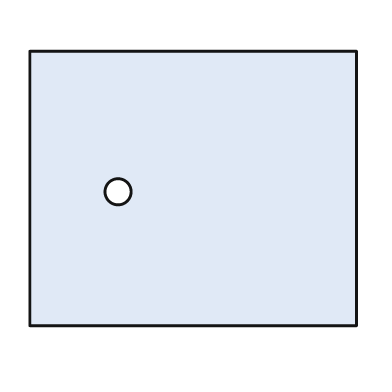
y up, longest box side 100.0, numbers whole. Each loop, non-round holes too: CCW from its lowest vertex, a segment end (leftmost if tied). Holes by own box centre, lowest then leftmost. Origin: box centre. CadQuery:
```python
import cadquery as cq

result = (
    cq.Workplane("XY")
    .moveTo(-50.0, -42.0)
    .lineTo(50.0, -42.0)
    .lineTo(50.0, 42.0)
    .lineTo(-50.0, 42.0)
    .close()
    .moveTo(-23.0, -1.0)
    .circle(4.0)
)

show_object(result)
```